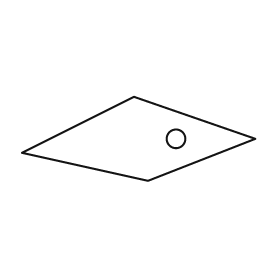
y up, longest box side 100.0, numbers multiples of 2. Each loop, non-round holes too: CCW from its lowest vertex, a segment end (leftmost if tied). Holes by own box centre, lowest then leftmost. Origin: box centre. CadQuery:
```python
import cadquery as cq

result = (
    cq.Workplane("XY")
    .moveTo(4.0, -18.0)
    .lineTo(50.0, 0.0)
    .lineTo(-2.0, 18.0)
    .lineTo(-50.0, -6.0)
    .close()
    .moveTo(16.0, 0.0)
    .circle(4.0)
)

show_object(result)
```